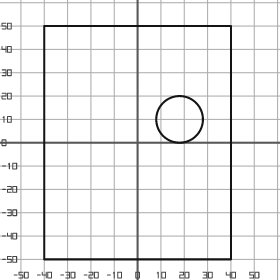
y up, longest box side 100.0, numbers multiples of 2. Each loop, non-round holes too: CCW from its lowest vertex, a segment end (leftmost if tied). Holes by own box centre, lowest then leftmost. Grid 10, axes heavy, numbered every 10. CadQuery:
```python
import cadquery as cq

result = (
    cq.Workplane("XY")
    .moveTo(-40.0, -50.0)
    .lineTo(40.0, -50.0)
    .lineTo(40.0, 50.0)
    .lineTo(-40.0, 50.0)
    .close()
    .moveTo(18.0, 10.0)
    .circle(10.0)
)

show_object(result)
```